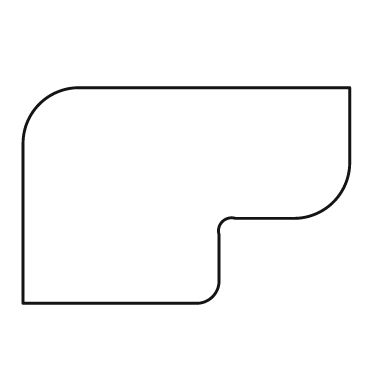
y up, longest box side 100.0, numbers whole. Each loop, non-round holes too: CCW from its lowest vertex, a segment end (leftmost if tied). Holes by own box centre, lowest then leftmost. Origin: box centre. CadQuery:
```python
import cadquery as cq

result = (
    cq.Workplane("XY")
    .moveTo(-50.0, -33.0)
    .lineTo(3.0, -33.0)
    .threePointArc((8.0, -31.0), (10.0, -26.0))
    .lineTo(10.0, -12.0)
    .threePointArc((11.0, -8.0), (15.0, -7.0))
    .lineTo(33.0, -7.0)
    .threePointArc((45.0, -2.0), (50.0, 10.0))
    .lineTo(50.0, 33.0)
    .lineTo(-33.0, 33.0)
    .threePointArc((-45.0, 28.0), (-50.0, 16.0))
    .close()
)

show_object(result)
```